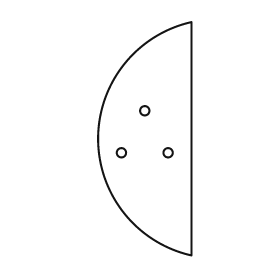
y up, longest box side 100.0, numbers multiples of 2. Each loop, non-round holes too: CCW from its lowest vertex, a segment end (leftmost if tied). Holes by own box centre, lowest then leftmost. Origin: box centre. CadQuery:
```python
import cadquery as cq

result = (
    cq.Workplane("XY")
    .moveTo(20.0, -50.0)
    .lineTo(20.0, 50.0)
    .threePointArc((-20.0, 0.0), (20.0, -50.0))
    .close()
    .moveTo(-10.0, -6.0)
    .circle(2.0)
    .moveTo(10.0, -6.0)
    .circle(2.0)
    .moveTo(0.0, 12.0)
    .circle(2.0)
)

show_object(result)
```